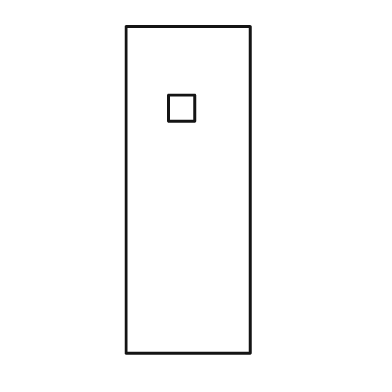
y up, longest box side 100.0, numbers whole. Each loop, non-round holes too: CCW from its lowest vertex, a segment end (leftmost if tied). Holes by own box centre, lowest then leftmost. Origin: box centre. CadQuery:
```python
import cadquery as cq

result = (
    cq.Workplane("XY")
    .moveTo(-19.0, -50.0)
    .lineTo(19.0, -50.0)
    .lineTo(19.0, 50.0)
    .lineTo(-19.0, 50.0)
    .close()
    .moveTo(-6.0, 21.0)
    .lineTo(2.0, 21.0)
    .lineTo(2.0, 29.0)
    .lineTo(-6.0, 29.0)
    .close()
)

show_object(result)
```